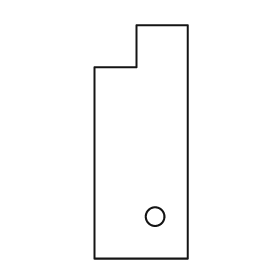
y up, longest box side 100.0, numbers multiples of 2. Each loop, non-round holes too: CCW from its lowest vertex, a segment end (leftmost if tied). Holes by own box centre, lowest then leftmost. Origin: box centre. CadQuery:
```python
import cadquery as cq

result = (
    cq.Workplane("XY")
    .moveTo(-20.0, -50.0)
    .lineTo(20.0, -50.0)
    .lineTo(20.0, 50.0)
    .lineTo(-2.0, 50.0)
    .lineTo(-2.0, 32.0)
    .lineTo(-20.0, 32.0)
    .close()
    .moveTo(6.0, -32.0)
    .circle(4.0)
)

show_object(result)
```